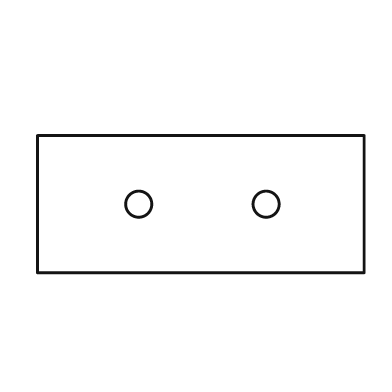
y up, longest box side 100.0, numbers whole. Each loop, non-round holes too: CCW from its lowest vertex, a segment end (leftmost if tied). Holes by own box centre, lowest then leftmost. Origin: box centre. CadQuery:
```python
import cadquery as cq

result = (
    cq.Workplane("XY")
    .moveTo(-50.0, -21.0)
    .lineTo(50.0, -21.0)
    .lineTo(50.0, 21.0)
    .lineTo(-50.0, 21.0)
    .close()
    .moveTo(-19.0, 0.0)
    .circle(4.0)
    .moveTo(20.0, 0.0)
    .circle(4.0)
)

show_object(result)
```